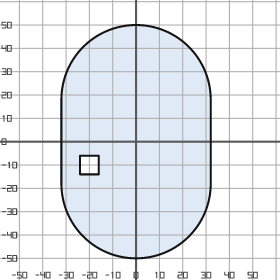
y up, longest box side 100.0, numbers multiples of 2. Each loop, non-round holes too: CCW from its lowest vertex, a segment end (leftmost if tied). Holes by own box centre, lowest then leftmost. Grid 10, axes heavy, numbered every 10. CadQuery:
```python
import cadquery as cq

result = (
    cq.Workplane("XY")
    .moveTo(-32.0, -18.0)
    .threePointArc((0.0, -50.0), (32.0, -18.0))
    .lineTo(32.0, 18.0)
    .threePointArc((0.0, 50.0), (-32.0, 18.0))
    .close()
    .moveTo(-24.0, -14.0)
    .lineTo(-16.0, -14.0)
    .lineTo(-16.0, -6.0)
    .lineTo(-24.0, -6.0)
    .close()
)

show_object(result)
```